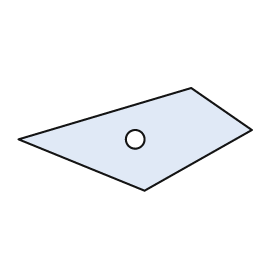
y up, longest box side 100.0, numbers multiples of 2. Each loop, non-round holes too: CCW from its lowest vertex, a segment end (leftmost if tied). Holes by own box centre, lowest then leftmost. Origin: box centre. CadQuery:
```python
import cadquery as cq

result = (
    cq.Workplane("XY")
    .moveTo(4.0, -22.0)
    .lineTo(50.0, 4.0)
    .lineTo(24.0, 22.0)
    .lineTo(-50.0, 0.0)
    .close()
    .moveTo(0.0, 0.0)
    .circle(4.0)
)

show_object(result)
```